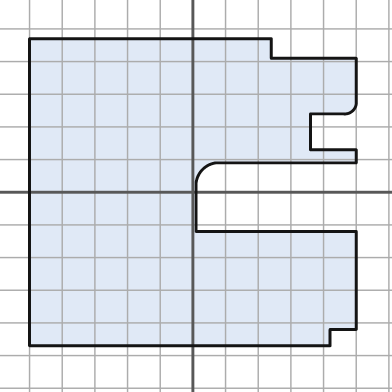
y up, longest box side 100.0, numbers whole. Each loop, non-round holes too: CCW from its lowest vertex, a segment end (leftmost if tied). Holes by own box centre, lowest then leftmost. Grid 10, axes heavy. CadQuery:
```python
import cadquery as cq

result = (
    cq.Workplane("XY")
    .moveTo(-50.0, -47.0)
    .lineTo(42.0, -47.0)
    .lineTo(42.0, -42.0)
    .lineTo(50.0, -42.0)
    .lineTo(50.0, -12.0)
    .lineTo(1.0, -12.0)
    .lineTo(1.0, 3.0)
    .threePointArc((3.0, 7.0), (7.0, 9.0))
    .lineTo(50.0, 9.0)
    .lineTo(50.0, 13.0)
    .lineTo(36.0, 13.0)
    .lineTo(36.0, 24.0)
    .lineTo(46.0, 24.0)
    .threePointArc((49.0, 25.0), (50.0, 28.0))
    .lineTo(50.0, 41.0)
    .lineTo(24.0, 41.0)
    .lineTo(24.0, 47.0)
    .lineTo(-50.0, 47.0)
    .close()
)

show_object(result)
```